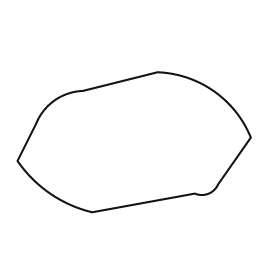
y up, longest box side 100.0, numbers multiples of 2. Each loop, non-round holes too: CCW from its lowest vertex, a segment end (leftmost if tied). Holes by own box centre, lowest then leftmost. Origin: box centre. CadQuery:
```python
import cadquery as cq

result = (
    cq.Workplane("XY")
    .moveTo(-18.0, -30.0)
    .lineTo(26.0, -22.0)
    .threePointArc((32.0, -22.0), (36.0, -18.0))
    .lineTo(50.0, 2.0)
    .threePointArc((34.0, 22.0), (10.0, 30.0))
    .lineTo(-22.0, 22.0)
    .threePointArc((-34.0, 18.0), (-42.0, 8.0))
    .lineTo(-50.0, -8.0)
    .threePointArc((-36.0, -22.0), (-18.0, -30.0))
    .close()
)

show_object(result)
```